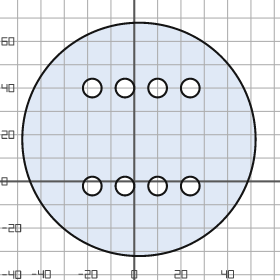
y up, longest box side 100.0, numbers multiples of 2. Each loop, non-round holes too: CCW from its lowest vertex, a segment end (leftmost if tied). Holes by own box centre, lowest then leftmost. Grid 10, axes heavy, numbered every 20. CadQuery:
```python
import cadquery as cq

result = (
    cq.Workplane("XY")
    .moveTo(2.0, 18.0)
    .circle(50.0)
    .moveTo(-18.0, -2.0)
    .circle(4.0)
    .moveTo(-4.0, -2.0)
    .circle(4.0)
    .moveTo(10.0, -2.0)
    .circle(4.0)
    .moveTo(24.0, -2.0)
    .circle(4.0)
    .moveTo(-18.0, 40.0)
    .circle(4.0)
    .moveTo(-4.0, 40.0)
    .circle(4.0)
    .moveTo(10.0, 40.0)
    .circle(4.0)
    .moveTo(24.0, 40.0)
    .circle(4.0)
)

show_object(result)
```